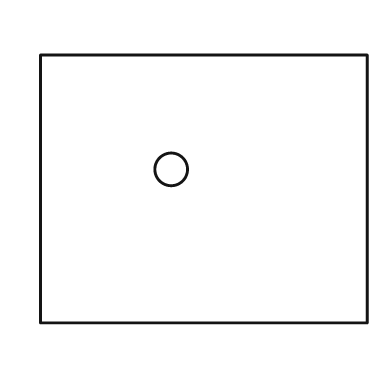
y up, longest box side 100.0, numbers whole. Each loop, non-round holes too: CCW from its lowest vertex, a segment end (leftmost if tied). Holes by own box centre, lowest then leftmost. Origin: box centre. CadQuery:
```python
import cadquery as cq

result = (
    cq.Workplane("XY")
    .moveTo(-50.0, -41.0)
    .lineTo(50.0, -41.0)
    .lineTo(50.0, 41.0)
    .lineTo(-50.0, 41.0)
    .close()
    .moveTo(-10.0, 6.0)
    .circle(5.0)
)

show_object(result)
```